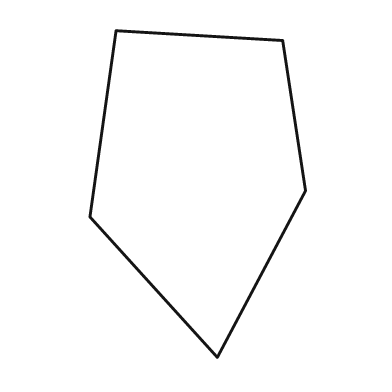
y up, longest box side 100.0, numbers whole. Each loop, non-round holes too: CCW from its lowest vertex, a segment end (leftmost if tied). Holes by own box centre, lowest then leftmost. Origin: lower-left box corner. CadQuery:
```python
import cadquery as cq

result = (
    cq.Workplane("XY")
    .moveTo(39.0, 0.0)
    .lineTo(66.0, 51.0)
    .lineTo(59.0, 97.0)
    .lineTo(8.0, 100.0)
    .lineTo(0.0, 43.0)
    .close()
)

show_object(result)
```